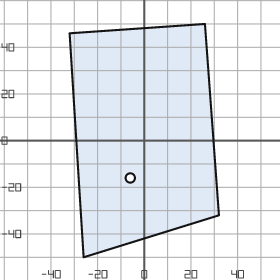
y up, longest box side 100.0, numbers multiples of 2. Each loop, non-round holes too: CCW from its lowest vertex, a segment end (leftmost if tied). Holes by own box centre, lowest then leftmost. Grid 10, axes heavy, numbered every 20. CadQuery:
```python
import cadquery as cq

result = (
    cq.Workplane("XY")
    .moveTo(-26.0, -50.0)
    .lineTo(32.0, -32.0)
    .lineTo(26.0, 50.0)
    .lineTo(-32.0, 46.0)
    .close()
    .moveTo(-6.0, -16.0)
    .circle(2.0)
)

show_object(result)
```